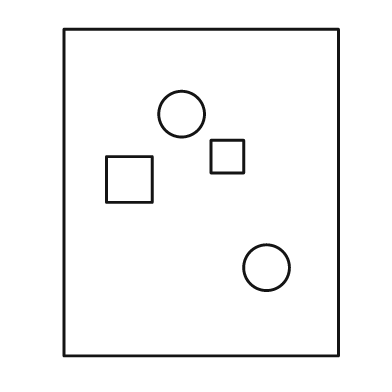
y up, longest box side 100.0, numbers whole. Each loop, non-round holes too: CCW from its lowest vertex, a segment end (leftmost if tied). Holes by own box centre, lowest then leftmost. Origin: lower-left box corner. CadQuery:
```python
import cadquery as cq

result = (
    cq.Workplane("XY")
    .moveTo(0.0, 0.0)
    .lineTo(84.0, 0.0)
    .lineTo(84.0, 100.0)
    .lineTo(0.0, 100.0)
    .close()
    .moveTo(62.0, 27.0)
    .circle(7.0)
    .moveTo(13.0, 47.0)
    .lineTo(27.0, 47.0)
    .lineTo(27.0, 61.0)
    .lineTo(13.0, 61.0)
    .close()
    .moveTo(45.0, 56.0)
    .lineTo(55.0, 56.0)
    .lineTo(55.0, 66.0)
    .lineTo(45.0, 66.0)
    .close()
    .moveTo(36.0, 74.0)
    .circle(7.0)
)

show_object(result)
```